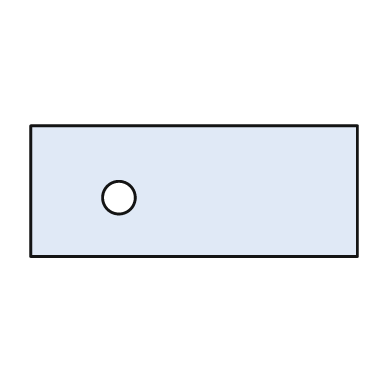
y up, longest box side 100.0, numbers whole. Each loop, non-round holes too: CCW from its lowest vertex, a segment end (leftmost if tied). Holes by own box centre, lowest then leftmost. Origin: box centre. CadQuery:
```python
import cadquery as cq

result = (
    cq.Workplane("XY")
    .moveTo(-50.0, -20.0)
    .lineTo(50.0, -20.0)
    .lineTo(50.0, 20.0)
    .lineTo(-50.0, 20.0)
    .close()
    .moveTo(-23.0, -2.0)
    .circle(5.0)
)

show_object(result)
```